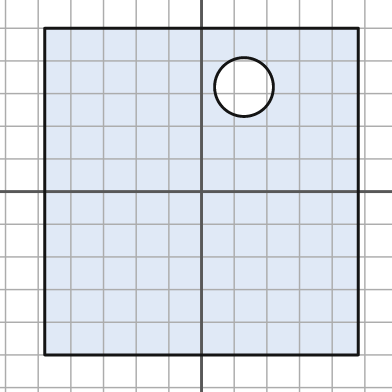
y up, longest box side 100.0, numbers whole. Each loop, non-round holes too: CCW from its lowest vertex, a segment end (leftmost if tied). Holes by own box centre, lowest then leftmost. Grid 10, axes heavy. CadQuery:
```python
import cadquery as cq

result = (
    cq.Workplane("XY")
    .moveTo(-48.0, -50.0)
    .lineTo(48.0, -50.0)
    .lineTo(48.0, 50.0)
    .lineTo(-48.0, 50.0)
    .close()
    .moveTo(13.0, 32.0)
    .circle(9.0)
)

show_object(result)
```